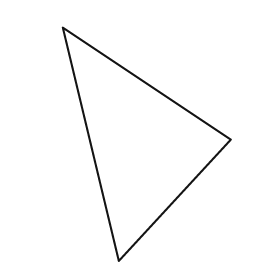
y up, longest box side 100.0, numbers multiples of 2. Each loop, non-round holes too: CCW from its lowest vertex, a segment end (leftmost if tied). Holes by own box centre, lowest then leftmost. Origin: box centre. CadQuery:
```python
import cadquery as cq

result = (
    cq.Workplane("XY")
    .moveTo(-12.0, -50.0)
    .lineTo(36.0, 2.0)
    .lineTo(-36.0, 50.0)
    .close()
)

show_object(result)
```